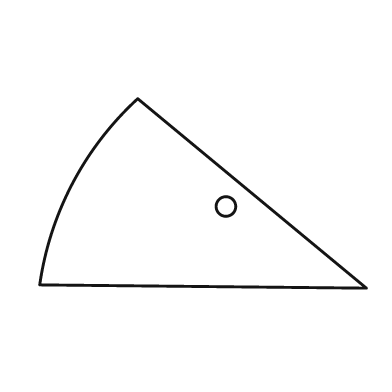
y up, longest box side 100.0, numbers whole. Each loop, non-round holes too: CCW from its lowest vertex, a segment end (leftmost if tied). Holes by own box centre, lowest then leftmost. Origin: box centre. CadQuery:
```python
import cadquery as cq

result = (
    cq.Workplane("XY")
    .moveTo(50.0, -29.0)
    .lineTo(-20.0, 29.0)
    .threePointArc((-40.0, 3.0), (-50.0, -28.0))
    .close()
    .moveTo(7.0, -4.0)
    .circle(3.0)
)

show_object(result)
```